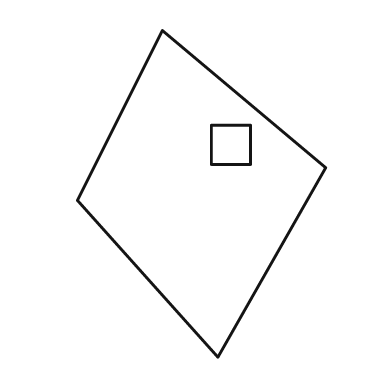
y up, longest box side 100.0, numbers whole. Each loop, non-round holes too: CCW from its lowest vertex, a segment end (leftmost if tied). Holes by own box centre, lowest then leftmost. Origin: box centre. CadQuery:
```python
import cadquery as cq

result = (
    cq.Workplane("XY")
    .moveTo(5.0, -50.0)
    .lineTo(38.0, 8.0)
    .lineTo(-12.0, 50.0)
    .lineTo(-38.0, -2.0)
    .close()
    .moveTo(3.0, 9.0)
    .lineTo(15.0, 9.0)
    .lineTo(15.0, 21.0)
    .lineTo(3.0, 21.0)
    .close()
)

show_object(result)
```